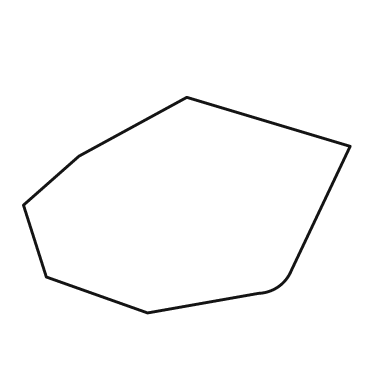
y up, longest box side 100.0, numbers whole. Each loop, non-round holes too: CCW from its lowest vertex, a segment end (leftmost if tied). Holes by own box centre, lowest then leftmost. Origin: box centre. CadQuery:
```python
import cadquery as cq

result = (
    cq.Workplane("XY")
    .moveTo(-12.0, -33.0)
    .lineTo(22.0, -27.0)
    .threePointArc((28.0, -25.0), (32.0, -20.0))
    .lineTo(50.0, 18.0)
    .lineTo(0.0, 33.0)
    .lineTo(-33.0, 15.0)
    .lineTo(-50.0, 0.0)
    .lineTo(-43.0, -22.0)
    .close()
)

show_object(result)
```